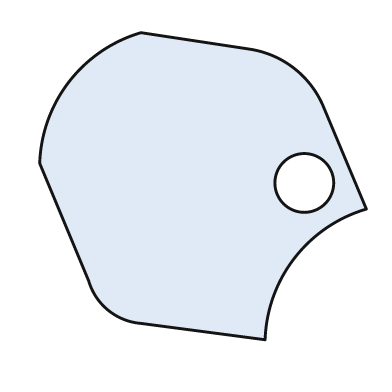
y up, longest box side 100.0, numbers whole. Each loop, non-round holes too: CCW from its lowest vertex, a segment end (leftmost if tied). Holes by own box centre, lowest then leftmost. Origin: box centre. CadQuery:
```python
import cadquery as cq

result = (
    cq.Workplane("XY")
    .moveTo(19.0, -47.0)
    .threePointArc((28.0, -22.0), (50.0, -7.0))
    .lineTo(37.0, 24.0)
    .threePointArc((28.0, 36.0), (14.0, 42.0))
    .lineTo(-19.0, 47.0)
    .threePointArc((-41.0, 32.0), (-50.0, 7.0))
    .lineTo(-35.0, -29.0)
    .threePointArc((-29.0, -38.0), (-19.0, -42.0))
    .close()
    .moveTo(31.0, 1.0)
    .circle(9.0)
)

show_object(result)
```